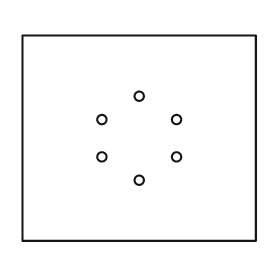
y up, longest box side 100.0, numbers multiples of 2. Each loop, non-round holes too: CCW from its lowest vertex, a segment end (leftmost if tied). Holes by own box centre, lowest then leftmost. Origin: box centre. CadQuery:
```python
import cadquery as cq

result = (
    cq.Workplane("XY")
    .moveTo(-50.0, -44.0)
    .lineTo(50.0, -44.0)
    .lineTo(50.0, 44.0)
    .lineTo(-50.0, 44.0)
    .close()
    .moveTo(0.0, -18.0)
    .circle(2.0)
    .moveTo(-16.0, -8.0)
    .circle(2.0)
    .moveTo(16.0, -8.0)
    .circle(2.0)
    .moveTo(-16.0, 8.0)
    .circle(2.0)
    .moveTo(16.0, 8.0)
    .circle(2.0)
    .moveTo(0.0, 18.0)
    .circle(2.0)
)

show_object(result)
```